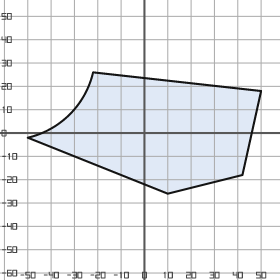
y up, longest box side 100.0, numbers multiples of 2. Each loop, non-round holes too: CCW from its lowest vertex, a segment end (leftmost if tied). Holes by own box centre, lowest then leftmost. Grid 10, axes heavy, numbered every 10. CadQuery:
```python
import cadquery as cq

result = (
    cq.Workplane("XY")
    .moveTo(10.0, -26.0)
    .lineTo(42.0, -18.0)
    .lineTo(50.0, 18.0)
    .lineTo(-22.0, 26.0)
    .threePointArc((-32.0, 8.0), (-50.0, -2.0))
    .close()
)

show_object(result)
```